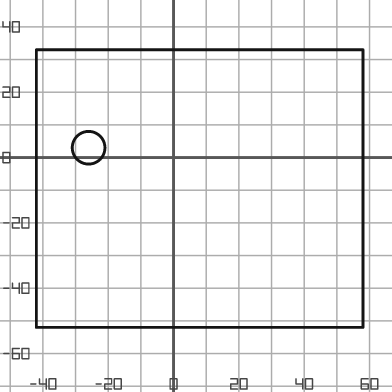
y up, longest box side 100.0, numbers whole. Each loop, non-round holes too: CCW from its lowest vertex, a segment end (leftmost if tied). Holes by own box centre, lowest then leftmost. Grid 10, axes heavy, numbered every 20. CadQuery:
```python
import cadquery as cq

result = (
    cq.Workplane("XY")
    .moveTo(-42.0, -52.0)
    .lineTo(58.0, -52.0)
    .lineTo(58.0, 33.0)
    .lineTo(-42.0, 33.0)
    .close()
    .moveTo(-26.0, 3.0)
    .circle(5.0)
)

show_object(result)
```